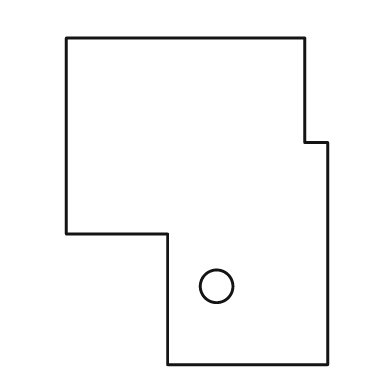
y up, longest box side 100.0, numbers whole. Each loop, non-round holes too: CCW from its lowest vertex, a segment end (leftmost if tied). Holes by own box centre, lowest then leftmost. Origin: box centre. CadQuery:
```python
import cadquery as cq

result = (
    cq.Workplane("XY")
    .moveTo(-9.0, -50.0)
    .lineTo(40.0, -50.0)
    .lineTo(40.0, 18.0)
    .lineTo(33.0, 18.0)
    .lineTo(33.0, 50.0)
    .lineTo(-40.0, 50.0)
    .lineTo(-40.0, -10.0)
    .lineTo(-9.0, -10.0)
    .close()
    .moveTo(6.0, -26.0)
    .circle(5.0)
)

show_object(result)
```